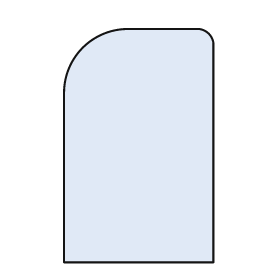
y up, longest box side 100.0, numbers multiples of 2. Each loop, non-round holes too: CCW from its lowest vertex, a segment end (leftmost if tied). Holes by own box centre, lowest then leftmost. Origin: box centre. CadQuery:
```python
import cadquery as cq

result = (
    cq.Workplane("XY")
    .moveTo(-32.0, -50.0)
    .lineTo(32.0, -50.0)
    .lineTo(32.0, 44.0)
    .threePointArc((30.0, 48.0), (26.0, 50.0))
    .lineTo(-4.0, 50.0)
    .threePointArc((-24.0, 42.0), (-32.0, 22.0))
    .close()
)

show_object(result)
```